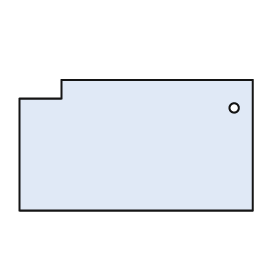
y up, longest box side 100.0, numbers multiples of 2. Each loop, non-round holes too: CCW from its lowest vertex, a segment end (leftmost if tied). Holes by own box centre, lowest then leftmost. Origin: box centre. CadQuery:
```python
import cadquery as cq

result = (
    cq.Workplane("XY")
    .moveTo(-50.0, -28.0)
    .lineTo(50.0, -28.0)
    .lineTo(50.0, 28.0)
    .lineTo(-32.0, 28.0)
    .lineTo(-32.0, 20.0)
    .lineTo(-50.0, 20.0)
    .close()
    .moveTo(42.0, 16.0)
    .circle(2.0)
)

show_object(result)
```